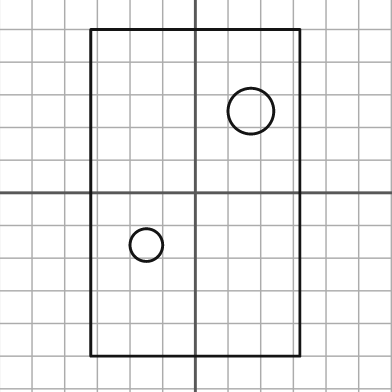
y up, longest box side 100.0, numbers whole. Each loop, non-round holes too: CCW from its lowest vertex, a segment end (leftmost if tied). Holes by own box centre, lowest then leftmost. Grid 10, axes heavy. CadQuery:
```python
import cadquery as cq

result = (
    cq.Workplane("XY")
    .moveTo(-32.0, -50.0)
    .lineTo(32.0, -50.0)
    .lineTo(32.0, 50.0)
    .lineTo(-32.0, 50.0)
    .close()
    .moveTo(-15.0, -16.0)
    .circle(5.0)
    .moveTo(17.0, 25.0)
    .circle(7.0)
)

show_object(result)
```